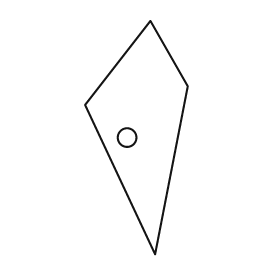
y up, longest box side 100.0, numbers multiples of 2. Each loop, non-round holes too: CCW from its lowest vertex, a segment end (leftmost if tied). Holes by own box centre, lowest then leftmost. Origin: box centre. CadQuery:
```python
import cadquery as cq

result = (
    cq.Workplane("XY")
    .moveTo(8.0, -50.0)
    .lineTo(22.0, 22.0)
    .lineTo(6.0, 50.0)
    .lineTo(-22.0, 14.0)
    .close()
    .moveTo(-4.0, 0.0)
    .circle(4.0)
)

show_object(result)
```